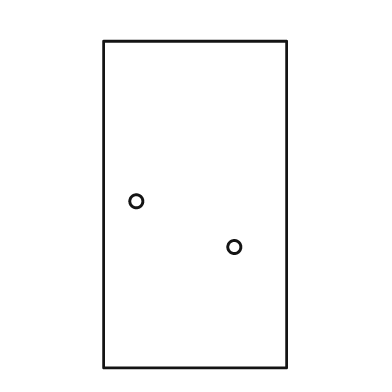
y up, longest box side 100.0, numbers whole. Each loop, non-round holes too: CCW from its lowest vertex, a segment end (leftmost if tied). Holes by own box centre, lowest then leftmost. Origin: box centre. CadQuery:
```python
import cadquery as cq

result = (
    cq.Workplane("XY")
    .moveTo(-28.0, -50.0)
    .lineTo(28.0, -50.0)
    .lineTo(28.0, 50.0)
    .lineTo(-28.0, 50.0)
    .close()
    .moveTo(12.0, -13.0)
    .circle(2.0)
    .moveTo(-18.0, 1.0)
    .circle(2.0)
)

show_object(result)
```